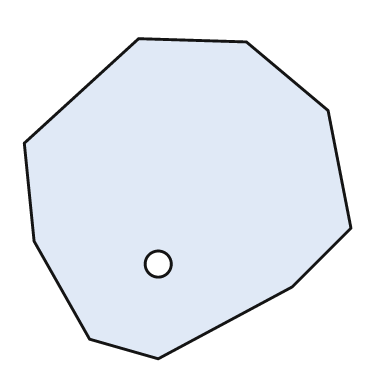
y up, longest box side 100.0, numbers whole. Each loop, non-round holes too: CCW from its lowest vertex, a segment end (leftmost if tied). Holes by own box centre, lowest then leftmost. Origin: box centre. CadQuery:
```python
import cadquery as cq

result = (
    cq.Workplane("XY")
    .moveTo(-9.0, -49.0)
    .lineTo(32.0, -27.0)
    .lineTo(50.0, -9.0)
    .lineTo(43.0, 27.0)
    .lineTo(18.0, 48.0)
    .lineTo(-15.0, 49.0)
    .lineTo(-50.0, 17.0)
    .lineTo(-47.0, -13.0)
    .lineTo(-30.0, -43.0)
    .close()
    .moveTo(-9.0, -20.0)
    .circle(4.0)
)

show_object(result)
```